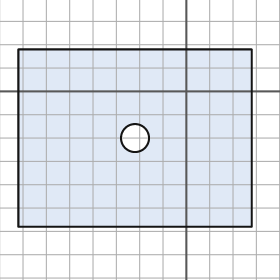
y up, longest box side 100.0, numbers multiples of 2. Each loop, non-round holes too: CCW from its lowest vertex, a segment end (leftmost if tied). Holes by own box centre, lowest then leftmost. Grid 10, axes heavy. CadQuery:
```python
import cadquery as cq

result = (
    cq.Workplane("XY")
    .moveTo(-72.0, -58.0)
    .lineTo(28.0, -58.0)
    .lineTo(28.0, 18.0)
    .lineTo(-72.0, 18.0)
    .close()
    .moveTo(-22.0, -20.0)
    .circle(6.0)
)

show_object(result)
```